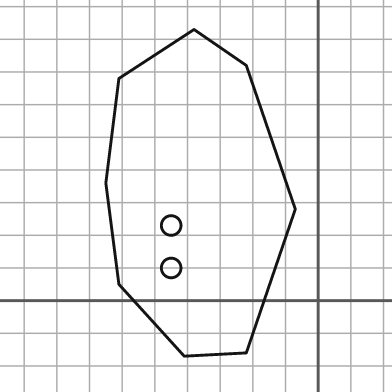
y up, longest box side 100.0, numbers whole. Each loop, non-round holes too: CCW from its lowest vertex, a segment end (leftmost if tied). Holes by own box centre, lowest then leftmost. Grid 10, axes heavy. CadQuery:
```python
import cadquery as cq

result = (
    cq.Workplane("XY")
    .moveTo(-41.0, -17.0)
    .lineTo(-22.0, -16.0)
    .lineTo(-7.0, 28.0)
    .lineTo(-22.0, 72.0)
    .lineTo(-38.0, 83.0)
    .lineTo(-61.0, 68.0)
    .lineTo(-65.0, 36.0)
    .lineTo(-61.0, 5.0)
    .close()
    .moveTo(-45.0, 10.0)
    .circle(3.0)
    .moveTo(-45.0, 23.0)
    .circle(3.0)
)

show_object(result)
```